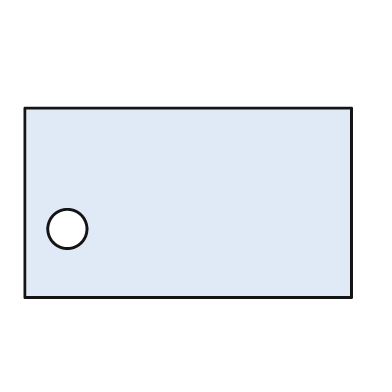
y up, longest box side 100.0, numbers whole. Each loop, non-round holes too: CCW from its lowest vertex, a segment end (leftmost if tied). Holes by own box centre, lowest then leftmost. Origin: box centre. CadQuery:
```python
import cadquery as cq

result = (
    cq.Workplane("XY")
    .moveTo(-50.0, -29.0)
    .lineTo(50.0, -29.0)
    .lineTo(50.0, 29.0)
    .lineTo(-50.0, 29.0)
    .close()
    .moveTo(-37.0, -8.0)
    .circle(6.0)
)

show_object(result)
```